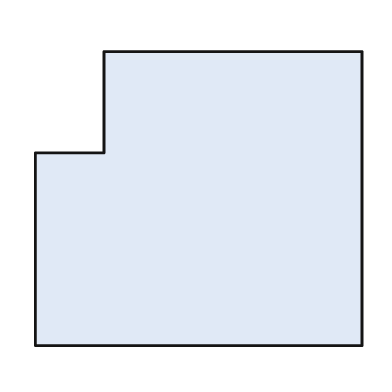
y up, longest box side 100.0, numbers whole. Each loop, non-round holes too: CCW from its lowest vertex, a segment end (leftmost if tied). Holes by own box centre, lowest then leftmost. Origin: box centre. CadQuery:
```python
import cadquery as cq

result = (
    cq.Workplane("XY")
    .moveTo(-50.0, -45.0)
    .lineTo(50.0, -45.0)
    .lineTo(50.0, 45.0)
    .lineTo(-29.0, 45.0)
    .lineTo(-29.0, 14.0)
    .lineTo(-50.0, 14.0)
    .close()
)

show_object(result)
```